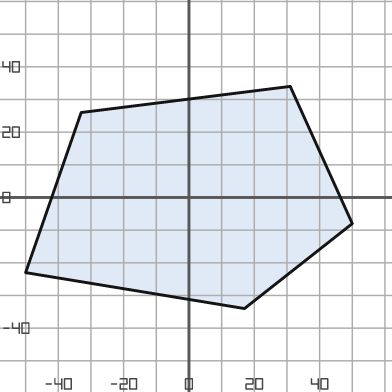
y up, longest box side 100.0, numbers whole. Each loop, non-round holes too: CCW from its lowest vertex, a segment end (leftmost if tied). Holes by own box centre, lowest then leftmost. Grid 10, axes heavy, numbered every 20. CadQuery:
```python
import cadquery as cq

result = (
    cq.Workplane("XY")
    .moveTo(17.0, -34.0)
    .lineTo(50.0, -8.0)
    .lineTo(31.0, 34.0)
    .lineTo(-33.0, 26.0)
    .lineTo(-50.0, -23.0)
    .close()
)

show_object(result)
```